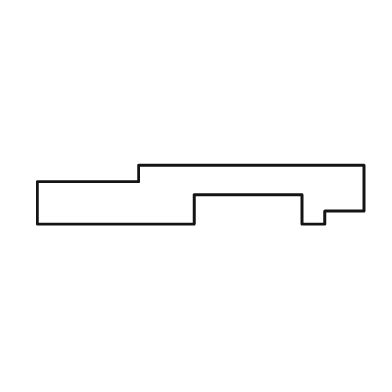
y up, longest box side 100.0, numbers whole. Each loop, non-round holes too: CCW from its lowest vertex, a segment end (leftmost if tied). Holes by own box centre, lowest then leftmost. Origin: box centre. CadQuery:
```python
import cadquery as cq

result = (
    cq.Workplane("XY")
    .moveTo(-50.0, -9.0)
    .lineTo(-2.0, -9.0)
    .lineTo(-2.0, 0.0)
    .lineTo(31.0, 0.0)
    .lineTo(31.0, -9.0)
    .lineTo(38.0, -9.0)
    .lineTo(38.0, -5.0)
    .lineTo(50.0, -5.0)
    .lineTo(50.0, 9.0)
    .lineTo(-19.0, 9.0)
    .lineTo(-19.0, 4.0)
    .lineTo(-50.0, 4.0)
    .close()
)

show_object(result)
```